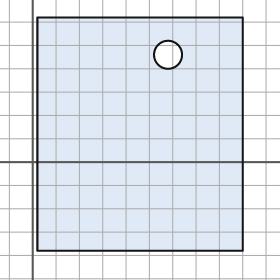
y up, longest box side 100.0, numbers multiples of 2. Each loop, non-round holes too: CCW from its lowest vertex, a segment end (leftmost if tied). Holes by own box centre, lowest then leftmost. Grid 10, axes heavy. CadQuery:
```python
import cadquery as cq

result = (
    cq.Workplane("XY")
    .moveTo(2.0, -38.0)
    .lineTo(90.0, -38.0)
    .lineTo(90.0, 62.0)
    .lineTo(2.0, 62.0)
    .close()
    .moveTo(58.0, 46.0)
    .circle(6.0)
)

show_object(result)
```